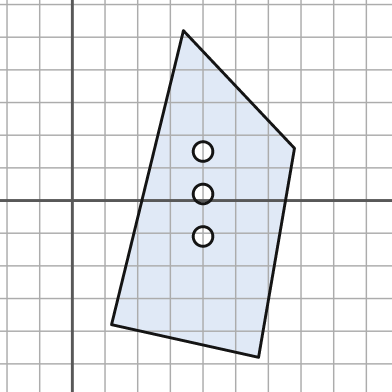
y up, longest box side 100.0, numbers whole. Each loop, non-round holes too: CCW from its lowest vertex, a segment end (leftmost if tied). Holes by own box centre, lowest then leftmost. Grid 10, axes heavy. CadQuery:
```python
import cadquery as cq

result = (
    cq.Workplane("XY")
    .moveTo(57.0, -48.0)
    .lineTo(68.0, 16.0)
    .lineTo(34.0, 52.0)
    .lineTo(12.0, -38.0)
    .close()
    .moveTo(40.0, -11.0)
    .circle(3.0)
    .moveTo(40.0, 2.0)
    .circle(3.0)
    .moveTo(40.0, 15.0)
    .circle(3.0)
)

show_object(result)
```